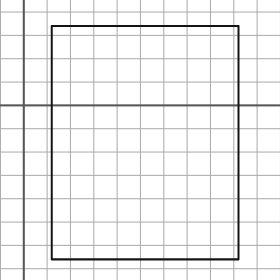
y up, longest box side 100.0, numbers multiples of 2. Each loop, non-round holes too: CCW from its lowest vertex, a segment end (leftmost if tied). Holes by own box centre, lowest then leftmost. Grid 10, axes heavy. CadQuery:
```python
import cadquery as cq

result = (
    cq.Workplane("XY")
    .moveTo(12.0, -66.0)
    .lineTo(92.0, -66.0)
    .lineTo(92.0, 34.0)
    .lineTo(12.0, 34.0)
    .close()
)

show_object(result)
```